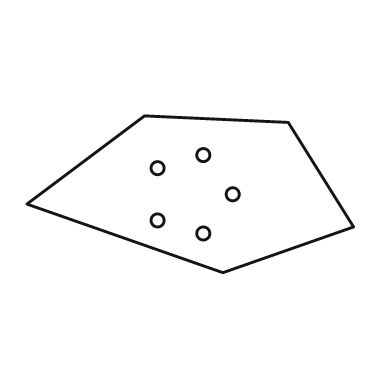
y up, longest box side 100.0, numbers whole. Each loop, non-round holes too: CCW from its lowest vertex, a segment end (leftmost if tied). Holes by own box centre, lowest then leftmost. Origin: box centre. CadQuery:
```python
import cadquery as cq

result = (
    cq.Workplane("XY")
    .moveTo(10.0, -24.0)
    .lineTo(50.0, -10.0)
    .lineTo(30.0, 22.0)
    .lineTo(-14.0, 24.0)
    .lineTo(-50.0, -3.0)
    .close()
    .moveTo(4.0, -12.0)
    .circle(2.0)
    .moveTo(-10.0, -8.0)
    .circle(2.0)
    .moveTo(13.0, 0.0)
    .circle(2.0)
    .moveTo(-10.0, 8.0)
    .circle(2.0)
    .moveTo(4.0, 12.0)
    .circle(2.0)
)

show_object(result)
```